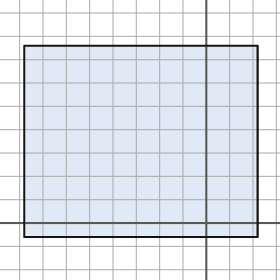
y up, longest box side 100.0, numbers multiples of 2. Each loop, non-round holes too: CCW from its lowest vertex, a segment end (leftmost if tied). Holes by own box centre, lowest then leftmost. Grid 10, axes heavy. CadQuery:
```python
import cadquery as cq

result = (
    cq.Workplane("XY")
    .moveTo(-78.0, -6.0)
    .lineTo(22.0, -6.0)
    .lineTo(22.0, 76.0)
    .lineTo(-78.0, 76.0)
    .close()
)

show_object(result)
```